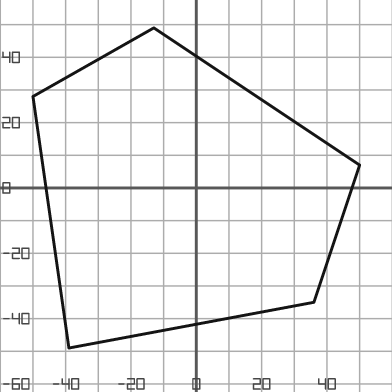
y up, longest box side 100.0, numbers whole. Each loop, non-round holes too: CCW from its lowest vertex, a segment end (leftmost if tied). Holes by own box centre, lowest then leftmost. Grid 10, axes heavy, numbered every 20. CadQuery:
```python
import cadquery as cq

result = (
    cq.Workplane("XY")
    .moveTo(-39.0, -49.0)
    .lineTo(36.0, -35.0)
    .lineTo(50.0, 7.0)
    .lineTo(-13.0, 49.0)
    .lineTo(-50.0, 28.0)
    .close()
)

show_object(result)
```